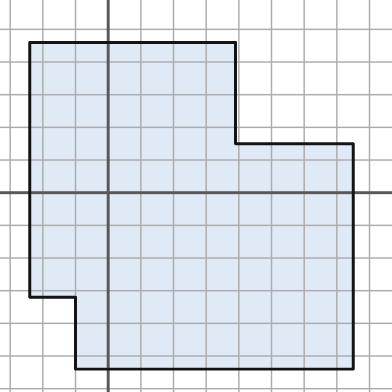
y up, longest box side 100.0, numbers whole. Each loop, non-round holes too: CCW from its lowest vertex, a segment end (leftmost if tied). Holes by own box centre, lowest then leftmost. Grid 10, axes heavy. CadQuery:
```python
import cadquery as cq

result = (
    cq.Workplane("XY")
    .moveTo(-10.0, -54.0)
    .lineTo(75.0, -54.0)
    .lineTo(75.0, 15.0)
    .lineTo(39.0, 15.0)
    .lineTo(39.0, 46.0)
    .lineTo(-24.0, 46.0)
    .lineTo(-24.0, -32.0)
    .lineTo(-10.0, -32.0)
    .close()
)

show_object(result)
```